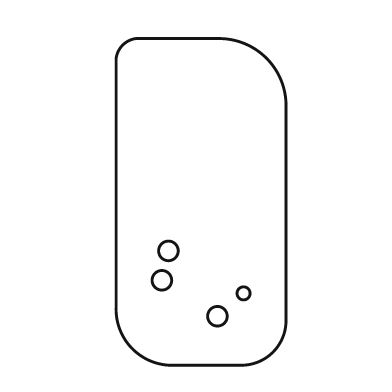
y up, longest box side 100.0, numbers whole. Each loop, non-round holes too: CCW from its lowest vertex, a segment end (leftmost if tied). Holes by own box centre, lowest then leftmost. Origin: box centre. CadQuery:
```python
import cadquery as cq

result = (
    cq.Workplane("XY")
    .moveTo(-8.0, -50.0)
    .lineTo(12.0, -50.0)
    .threePointArc((22.0, -46.0), (26.0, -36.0))
    .lineTo(26.0, 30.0)
    .threePointArc((20.0, 44.0), (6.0, 50.0))
    .lineTo(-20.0, 50.0)
    .threePointArc((-24.0, 48.0), (-26.0, 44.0))
    .lineTo(-26.0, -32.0)
    .threePointArc((-21.0, -45.0), (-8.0, -50.0))
    .close()
    .moveTo(5.0, -35.0)
    .circle(3.0)
    .moveTo(13.0, -28.0)
    .circle(2.0)
    .moveTo(-12.0, -24.0)
    .circle(3.0)
    .moveTo(-10.0, -15.0)
    .circle(3.0)
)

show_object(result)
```